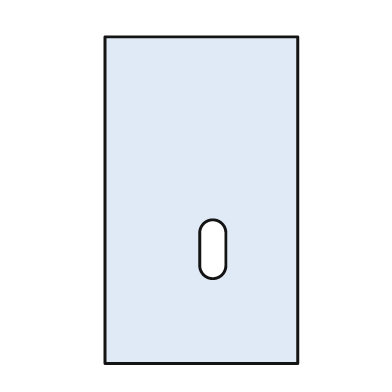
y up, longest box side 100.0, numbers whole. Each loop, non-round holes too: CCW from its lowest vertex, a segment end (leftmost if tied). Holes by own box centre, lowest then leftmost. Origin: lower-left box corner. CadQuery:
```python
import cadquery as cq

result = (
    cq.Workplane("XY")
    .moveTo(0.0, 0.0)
    .lineTo(59.0, 0.0)
    .lineTo(59.0, 100.0)
    .lineTo(0.0, 100.0)
    .close()
    .moveTo(29.0, 30.0)
    .threePointArc((33.0, 26.0), (37.0, 30.0))
    .lineTo(37.0, 40.0)
    .threePointArc((33.0, 44.0), (29.0, 40.0))
    .close()
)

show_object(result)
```